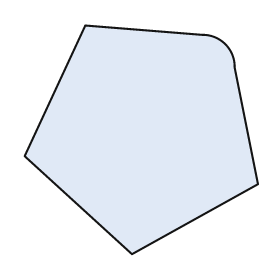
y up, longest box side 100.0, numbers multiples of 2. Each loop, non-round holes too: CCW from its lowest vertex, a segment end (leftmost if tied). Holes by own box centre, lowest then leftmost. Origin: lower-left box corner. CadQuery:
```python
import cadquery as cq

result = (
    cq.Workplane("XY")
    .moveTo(46.0, 0.0)
    .lineTo(100.0, 30.0)
    .lineTo(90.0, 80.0)
    .threePointArc((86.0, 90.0), (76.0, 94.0))
    .lineTo(26.0, 98.0)
    .lineTo(0.0, 42.0)
    .close()
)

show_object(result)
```